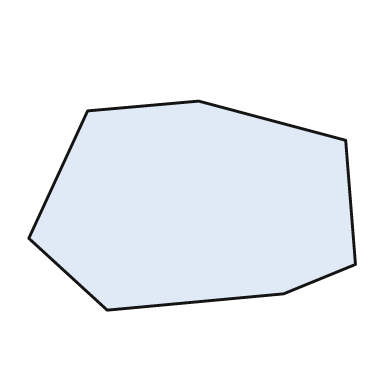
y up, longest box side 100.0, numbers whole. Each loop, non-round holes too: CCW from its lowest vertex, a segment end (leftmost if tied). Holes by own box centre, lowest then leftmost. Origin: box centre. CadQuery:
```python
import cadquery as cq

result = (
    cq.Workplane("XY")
    .moveTo(-26.0, -32.0)
    .lineTo(28.0, -27.0)
    .lineTo(50.0, -18.0)
    .lineTo(47.0, 20.0)
    .lineTo(2.0, 32.0)
    .lineTo(-32.0, 29.0)
    .lineTo(-50.0, -10.0)
    .close()
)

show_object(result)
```